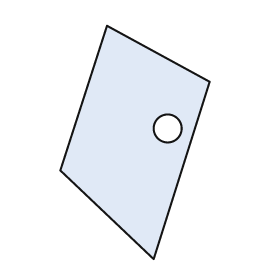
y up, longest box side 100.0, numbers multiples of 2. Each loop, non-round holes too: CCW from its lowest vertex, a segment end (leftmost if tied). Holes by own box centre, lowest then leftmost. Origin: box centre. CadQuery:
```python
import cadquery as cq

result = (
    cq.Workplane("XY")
    .moveTo(8.0, -50.0)
    .lineTo(32.0, 26.0)
    .lineTo(-12.0, 50.0)
    .lineTo(-32.0, -12.0)
    .close()
    .moveTo(14.0, 6.0)
    .circle(6.0)
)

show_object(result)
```